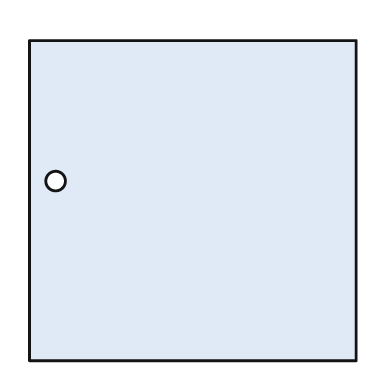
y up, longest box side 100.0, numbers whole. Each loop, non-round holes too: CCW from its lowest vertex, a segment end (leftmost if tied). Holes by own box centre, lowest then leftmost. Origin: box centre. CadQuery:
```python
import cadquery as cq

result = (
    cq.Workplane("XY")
    .moveTo(-50.0, -49.0)
    .lineTo(50.0, -49.0)
    .lineTo(50.0, 49.0)
    .lineTo(-50.0, 49.0)
    .close()
    .moveTo(-42.0, 6.0)
    .circle(3.0)
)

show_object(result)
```